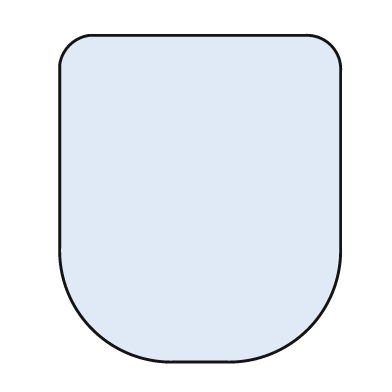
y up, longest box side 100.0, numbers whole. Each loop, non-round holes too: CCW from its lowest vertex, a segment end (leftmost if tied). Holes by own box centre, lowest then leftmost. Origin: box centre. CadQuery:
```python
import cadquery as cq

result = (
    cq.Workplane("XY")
    .moveTo(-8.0, -50.0)
    .lineTo(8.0, -50.0)
    .threePointArc((33.0, -40.0), (43.0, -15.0))
    .lineTo(43.0, 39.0)
    .threePointArc((40.0, 47.0), (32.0, 50.0))
    .lineTo(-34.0, 50.0)
    .threePointArc((-40.0, 47.0), (-43.0, 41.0))
    .lineTo(-43.0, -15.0)
    .threePointArc((-33.0, -40.0), (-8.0, -50.0))
    .close()
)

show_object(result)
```